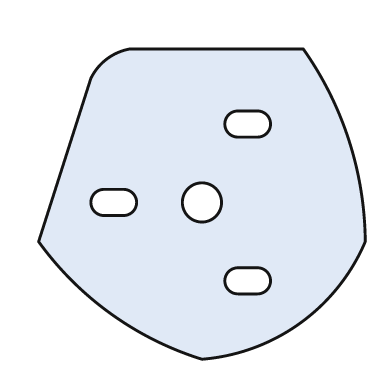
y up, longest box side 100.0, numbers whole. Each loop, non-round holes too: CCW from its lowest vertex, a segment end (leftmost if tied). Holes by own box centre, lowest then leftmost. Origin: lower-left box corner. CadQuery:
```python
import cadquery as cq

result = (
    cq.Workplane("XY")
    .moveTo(50.0, 0.0)
    .threePointArc((80.0, 11.0), (100.0, 36.0))
    .threePointArc((95.0, 67.0), (81.0, 95.0))
    .lineTo(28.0, 95.0)
    .threePointArc((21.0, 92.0), (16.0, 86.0))
    .lineTo(0.0, 36.0)
    .threePointArc((22.0, 14.0), (50.0, 0.0))
    .close()
    .moveTo(61.0, 20.0)
    .lineTo(67.0, 20.0)
    .threePointArc((71.0, 24.0), (67.0, 28.0))
    .lineTo(61.0, 28.0)
    .threePointArc((57.0, 24.0), (61.0, 20.0))
    .close()
    .moveTo(20.0, 44.0)
    .lineTo(26.0, 44.0)
    .threePointArc((30.0, 48.0), (26.0, 52.0))
    .lineTo(20.0, 52.0)
    .threePointArc((16.0, 48.0), (20.0, 44.0))
    .close()
    .moveTo(50.0, 48.0)
    .circle(6.0)
    .moveTo(61.0, 68.0)
    .lineTo(67.0, 68.0)
    .threePointArc((71.0, 72.0), (67.0, 76.0))
    .lineTo(61.0, 76.0)
    .threePointArc((57.0, 72.0), (61.0, 68.0))
    .close()
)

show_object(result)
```